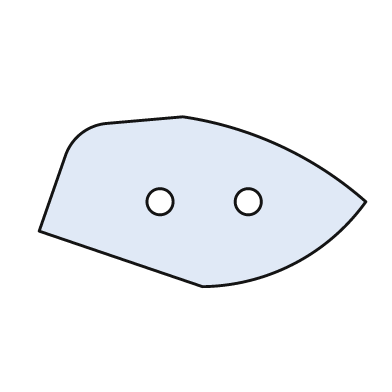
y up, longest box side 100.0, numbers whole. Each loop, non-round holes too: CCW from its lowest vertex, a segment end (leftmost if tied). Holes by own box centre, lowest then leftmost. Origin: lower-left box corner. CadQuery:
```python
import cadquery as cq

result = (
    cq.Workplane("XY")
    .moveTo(50.0, 0.0)
    .threePointArc((78.0, 7.0), (100.0, 26.0))
    .threePointArc((74.0, 43.0), (44.0, 52.0))
    .lineTo(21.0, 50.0)
    .threePointArc((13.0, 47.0), (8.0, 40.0))
    .lineTo(0.0, 17.0)
    .close()
    .moveTo(37.0, 26.0)
    .circle(4.0)
    .moveTo(64.0, 26.0)
    .circle(4.0)
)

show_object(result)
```